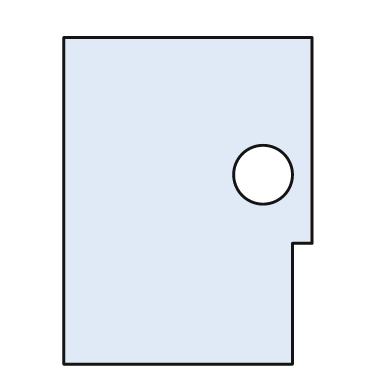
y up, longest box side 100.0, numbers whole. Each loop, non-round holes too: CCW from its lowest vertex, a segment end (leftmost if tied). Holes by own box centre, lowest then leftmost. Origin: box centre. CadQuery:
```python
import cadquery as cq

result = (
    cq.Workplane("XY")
    .moveTo(-38.0, -50.0)
    .lineTo(32.0, -50.0)
    .lineTo(32.0, -13.0)
    .lineTo(38.0, -13.0)
    .lineTo(38.0, 50.0)
    .lineTo(-38.0, 50.0)
    .close()
    .moveTo(23.0, 8.0)
    .circle(9.0)
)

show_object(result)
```